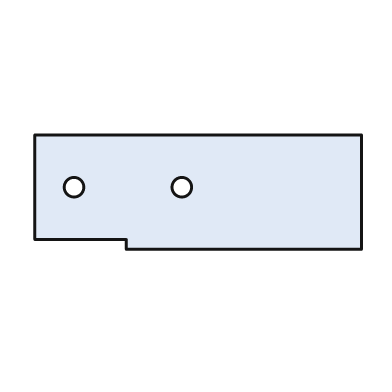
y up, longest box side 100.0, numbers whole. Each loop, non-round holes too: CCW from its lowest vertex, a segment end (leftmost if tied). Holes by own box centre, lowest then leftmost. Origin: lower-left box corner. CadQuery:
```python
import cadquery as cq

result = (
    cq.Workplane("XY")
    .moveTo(28.0, 0.0)
    .lineTo(100.0, 0.0)
    .lineTo(100.0, 35.0)
    .lineTo(0.0, 35.0)
    .lineTo(0.0, 3.0)
    .lineTo(28.0, 3.0)
    .close()
    .moveTo(12.0, 19.0)
    .circle(3.0)
    .moveTo(45.0, 19.0)
    .circle(3.0)
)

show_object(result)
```